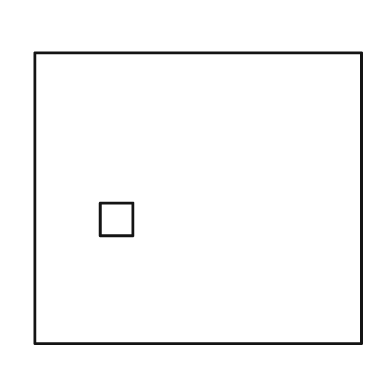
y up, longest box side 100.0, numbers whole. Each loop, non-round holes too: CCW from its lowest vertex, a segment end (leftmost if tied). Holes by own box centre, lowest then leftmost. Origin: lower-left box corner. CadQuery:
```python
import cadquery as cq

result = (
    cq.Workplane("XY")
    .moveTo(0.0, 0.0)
    .lineTo(100.0, 0.0)
    .lineTo(100.0, 89.0)
    .lineTo(0.0, 89.0)
    .close()
    .moveTo(20.0, 33.0)
    .lineTo(30.0, 33.0)
    .lineTo(30.0, 43.0)
    .lineTo(20.0, 43.0)
    .close()
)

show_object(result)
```